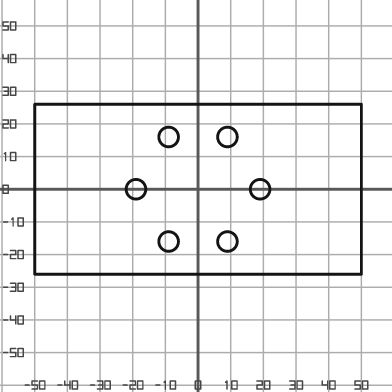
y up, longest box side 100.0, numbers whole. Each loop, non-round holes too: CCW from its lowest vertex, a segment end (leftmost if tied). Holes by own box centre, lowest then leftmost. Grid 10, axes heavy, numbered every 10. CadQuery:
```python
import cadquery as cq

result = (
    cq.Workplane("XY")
    .moveTo(-50.0, -26.0)
    .lineTo(50.0, -26.0)
    .lineTo(50.0, 26.0)
    .lineTo(-50.0, 26.0)
    .close()
    .moveTo(-9.0, -16.0)
    .circle(3.0)
    .moveTo(9.0, -16.0)
    .circle(3.0)
    .moveTo(-19.0, 0.0)
    .circle(3.0)
    .moveTo(19.0, 0.0)
    .circle(3.0)
    .moveTo(-9.0, 16.0)
    .circle(3.0)
    .moveTo(9.0, 16.0)
    .circle(3.0)
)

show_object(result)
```